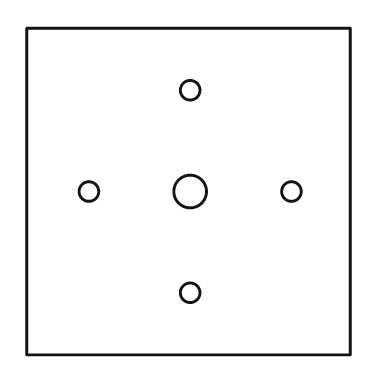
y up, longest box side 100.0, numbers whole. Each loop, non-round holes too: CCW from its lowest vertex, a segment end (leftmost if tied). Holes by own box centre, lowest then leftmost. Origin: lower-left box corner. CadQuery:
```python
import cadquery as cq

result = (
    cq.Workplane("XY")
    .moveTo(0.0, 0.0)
    .lineTo(99.0, 0.0)
    .lineTo(99.0, 100.0)
    .lineTo(0.0, 100.0)
    .close()
    .moveTo(50.0, 19.0)
    .circle(3.0)
    .moveTo(19.0, 50.0)
    .circle(3.0)
    .moveTo(50.0, 50.0)
    .circle(5.0)
    .moveTo(81.0, 50.0)
    .circle(3.0)
    .moveTo(50.0, 81.0)
    .circle(3.0)
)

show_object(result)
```